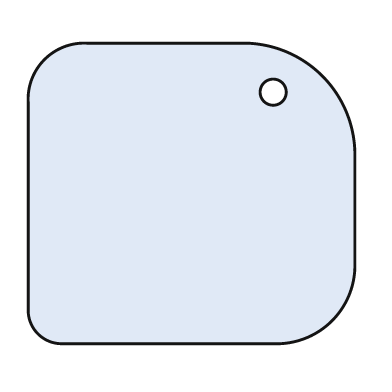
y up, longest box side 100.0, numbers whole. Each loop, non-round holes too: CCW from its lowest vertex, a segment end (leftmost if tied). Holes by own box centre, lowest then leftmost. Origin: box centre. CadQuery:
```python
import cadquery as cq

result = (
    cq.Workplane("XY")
    .moveTo(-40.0, -46.0)
    .lineTo(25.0, -46.0)
    .threePointArc((43.0, -39.0), (50.0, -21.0))
    .lineTo(50.0, 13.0)
    .threePointArc((40.0, 36.0), (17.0, 46.0))
    .lineTo(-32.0, 46.0)
    .threePointArc((-45.0, 41.0), (-50.0, 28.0))
    .lineTo(-50.0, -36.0)
    .threePointArc((-47.0, -43.0), (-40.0, -46.0))
    .close()
    .moveTo(25.0, 31.0)
    .circle(4.0)
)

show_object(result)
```